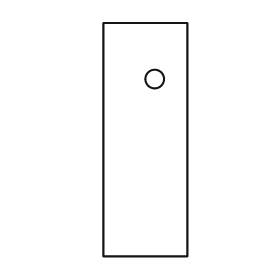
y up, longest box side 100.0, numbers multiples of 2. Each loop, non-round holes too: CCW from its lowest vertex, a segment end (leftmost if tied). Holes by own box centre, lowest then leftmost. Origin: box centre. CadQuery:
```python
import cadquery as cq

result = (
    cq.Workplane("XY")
    .moveTo(-18.0, -50.0)
    .lineTo(18.0, -50.0)
    .lineTo(18.0, 50.0)
    .lineTo(-18.0, 50.0)
    .close()
    .moveTo(4.0, 26.0)
    .circle(4.0)
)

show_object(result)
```